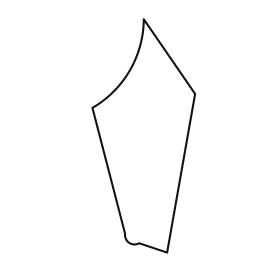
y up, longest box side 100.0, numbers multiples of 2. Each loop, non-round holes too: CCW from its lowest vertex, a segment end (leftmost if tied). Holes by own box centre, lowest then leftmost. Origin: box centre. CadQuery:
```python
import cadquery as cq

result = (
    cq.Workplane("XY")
    .moveTo(10.0, -50.0)
    .lineTo(22.0, 18.0)
    .lineTo(0.0, 50.0)
    .threePointArc((-6.0, 28.0), (-22.0, 12.0))
    .lineTo(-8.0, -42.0)
    .threePointArc((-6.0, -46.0), (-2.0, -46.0))
    .close()
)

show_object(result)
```